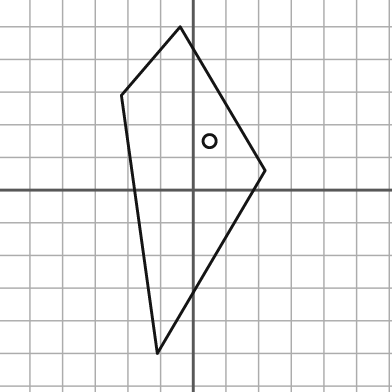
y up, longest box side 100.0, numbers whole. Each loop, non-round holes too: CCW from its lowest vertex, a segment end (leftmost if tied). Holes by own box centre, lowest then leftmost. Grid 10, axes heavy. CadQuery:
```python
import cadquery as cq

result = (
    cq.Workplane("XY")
    .moveTo(-11.0, -50.0)
    .lineTo(22.0, 6.0)
    .lineTo(-4.0, 50.0)
    .lineTo(-22.0, 29.0)
    .close()
    .moveTo(5.0, 15.0)
    .circle(2.0)
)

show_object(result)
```